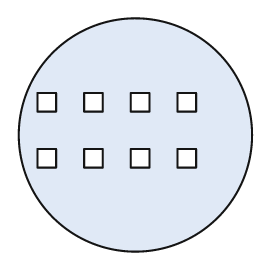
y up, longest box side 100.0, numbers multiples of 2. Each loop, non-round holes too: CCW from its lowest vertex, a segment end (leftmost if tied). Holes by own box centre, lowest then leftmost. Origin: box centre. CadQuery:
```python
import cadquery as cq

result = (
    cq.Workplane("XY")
    .moveTo(0.0, 0.0)
    .circle(50.0)
    .moveTo(-42.0, -14.0)
    .lineTo(-34.0, -14.0)
    .lineTo(-34.0, -6.0)
    .lineTo(-42.0, -6.0)
    .close()
    .moveTo(-22.0, -14.0)
    .lineTo(-14.0, -14.0)
    .lineTo(-14.0, -6.0)
    .lineTo(-22.0, -6.0)
    .close()
    .moveTo(-2.0, -14.0)
    .lineTo(6.0, -14.0)
    .lineTo(6.0, -6.0)
    .lineTo(-2.0, -6.0)
    .close()
    .moveTo(18.0, -14.0)
    .lineTo(26.0, -14.0)
    .lineTo(26.0, -6.0)
    .lineTo(18.0, -6.0)
    .close()
    .moveTo(-42.0, 10.0)
    .lineTo(-34.0, 10.0)
    .lineTo(-34.0, 18.0)
    .lineTo(-42.0, 18.0)
    .close()
    .moveTo(-22.0, 10.0)
    .lineTo(-14.0, 10.0)
    .lineTo(-14.0, 18.0)
    .lineTo(-22.0, 18.0)
    .close()
    .moveTo(-2.0, 10.0)
    .lineTo(6.0, 10.0)
    .lineTo(6.0, 18.0)
    .lineTo(-2.0, 18.0)
    .close()
    .moveTo(18.0, 10.0)
    .lineTo(26.0, 10.0)
    .lineTo(26.0, 18.0)
    .lineTo(18.0, 18.0)
    .close()
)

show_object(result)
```